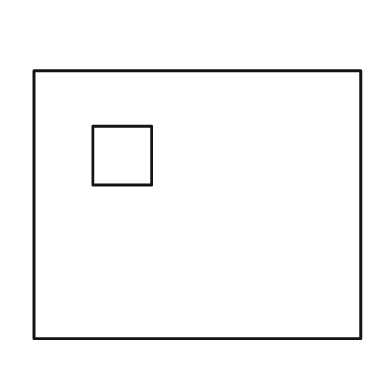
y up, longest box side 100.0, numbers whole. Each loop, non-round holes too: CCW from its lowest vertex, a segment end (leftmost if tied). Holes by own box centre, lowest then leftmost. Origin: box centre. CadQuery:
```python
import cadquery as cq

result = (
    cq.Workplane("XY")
    .moveTo(-50.0, -41.0)
    .lineTo(50.0, -41.0)
    .lineTo(50.0, 41.0)
    .lineTo(-50.0, 41.0)
    .close()
    .moveTo(-32.0, 6.0)
    .lineTo(-14.0, 6.0)
    .lineTo(-14.0, 24.0)
    .lineTo(-32.0, 24.0)
    .close()
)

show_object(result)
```